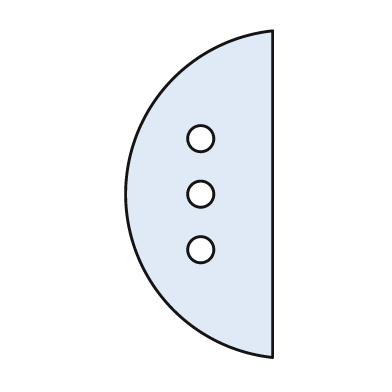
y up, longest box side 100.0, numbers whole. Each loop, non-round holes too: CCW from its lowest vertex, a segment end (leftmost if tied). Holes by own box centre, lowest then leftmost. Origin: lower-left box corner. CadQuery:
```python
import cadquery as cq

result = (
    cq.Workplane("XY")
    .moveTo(45.0, 0.0)
    .lineTo(45.0, 100.0)
    .threePointArc((0.0, 50.0), (45.0, 0.0))
    .close()
    .moveTo(23.0, 33.0)
    .circle(4.0)
    .moveTo(23.0, 50.0)
    .circle(4.0)
    .moveTo(23.0, 67.0)
    .circle(4.0)
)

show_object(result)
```